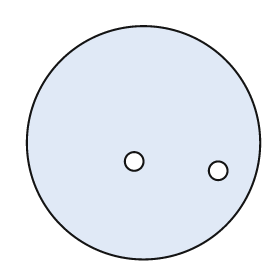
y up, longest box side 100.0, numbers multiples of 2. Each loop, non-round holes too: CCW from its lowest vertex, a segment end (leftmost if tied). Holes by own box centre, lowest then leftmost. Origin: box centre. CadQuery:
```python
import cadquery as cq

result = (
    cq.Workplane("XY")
    .moveTo(0.0, 0.0)
    .circle(50.0)
    .moveTo(32.0, -12.0)
    .circle(4.0)
    .moveTo(-4.0, -8.0)
    .circle(4.0)
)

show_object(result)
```